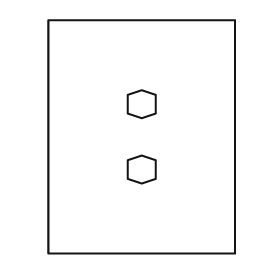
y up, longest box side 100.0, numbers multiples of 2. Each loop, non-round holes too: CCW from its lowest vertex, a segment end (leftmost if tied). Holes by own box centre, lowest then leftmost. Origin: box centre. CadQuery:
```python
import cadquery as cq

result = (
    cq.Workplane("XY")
    .moveTo(-40.0, -50.0)
    .lineTo(40.0, -50.0)
    .lineTo(40.0, 50.0)
    .lineTo(-40.0, 50.0)
    .close()
    .moveTo(0.0, -20.0)
    .lineTo(6.0, -18.0)
    .lineTo(6.0, -10.0)
    .lineTo(0.0, -8.0)
    .lineTo(-6.0, -10.0)
    .lineTo(-6.0, -18.0)
    .close()
    .moveTo(0.0, 8.0)
    .lineTo(6.0, 10.0)
    .lineTo(6.0, 18.0)
    .lineTo(0.0, 20.0)
    .lineTo(-6.0, 18.0)
    .lineTo(-6.0, 10.0)
    .close()
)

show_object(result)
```